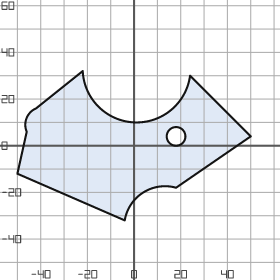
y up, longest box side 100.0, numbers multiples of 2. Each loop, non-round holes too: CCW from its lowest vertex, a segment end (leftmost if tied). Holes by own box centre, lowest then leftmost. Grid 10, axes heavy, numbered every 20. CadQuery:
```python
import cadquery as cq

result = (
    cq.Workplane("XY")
    .moveTo(-4.0, -32.0)
    .threePointArc((4.0, -20.0), (18.0, -18.0))
    .lineTo(50.0, 4.0)
    .lineTo(24.0, 30.0)
    .threePointArc((0.0, 10.0), (-22.0, 32.0))
    .lineTo(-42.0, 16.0)
    .threePointArc((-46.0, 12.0), (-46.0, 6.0))
    .lineTo(-50.0, -12.0)
    .close()
    .moveTo(18.0, 4.0)
    .circle(4.0)
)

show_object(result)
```